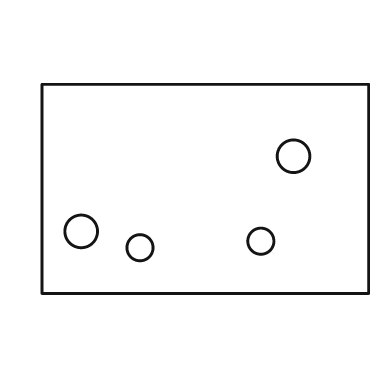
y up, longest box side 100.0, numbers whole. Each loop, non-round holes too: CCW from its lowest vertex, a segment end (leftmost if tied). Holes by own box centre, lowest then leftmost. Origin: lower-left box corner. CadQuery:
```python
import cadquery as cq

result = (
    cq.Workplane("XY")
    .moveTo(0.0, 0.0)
    .lineTo(100.0, 0.0)
    .lineTo(100.0, 64.0)
    .lineTo(0.0, 64.0)
    .close()
    .moveTo(30.0, 14.0)
    .circle(4.0)
    .moveTo(67.0, 16.0)
    .circle(4.0)
    .moveTo(12.0, 19.0)
    .circle(5.0)
    .moveTo(77.0, 42.0)
    .circle(5.0)
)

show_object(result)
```